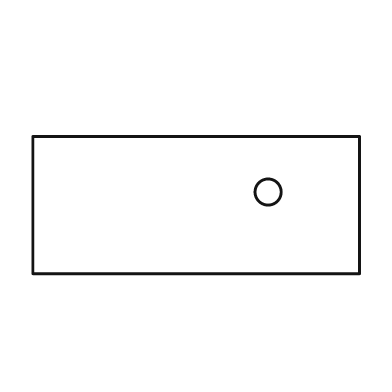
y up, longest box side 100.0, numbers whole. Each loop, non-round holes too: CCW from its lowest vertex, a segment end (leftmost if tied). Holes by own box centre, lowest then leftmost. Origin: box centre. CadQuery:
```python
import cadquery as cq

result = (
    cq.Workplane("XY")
    .moveTo(-50.0, -21.0)
    .lineTo(50.0, -21.0)
    .lineTo(50.0, 21.0)
    .lineTo(-50.0, 21.0)
    .close()
    .moveTo(22.0, 4.0)
    .circle(4.0)
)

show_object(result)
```